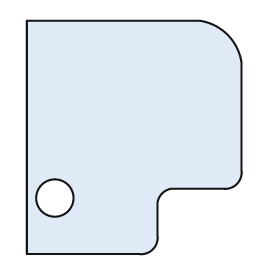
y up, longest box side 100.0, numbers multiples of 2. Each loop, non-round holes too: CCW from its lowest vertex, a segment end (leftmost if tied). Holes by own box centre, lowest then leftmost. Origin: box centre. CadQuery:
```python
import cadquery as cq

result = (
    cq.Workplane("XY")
    .moveTo(-46.0, -50.0)
    .lineTo(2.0, -50.0)
    .threePointArc((8.0, -48.0), (10.0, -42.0))
    .lineTo(10.0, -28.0)
    .threePointArc((12.0, -24.0), (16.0, -22.0))
    .lineTo(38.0, -22.0)
    .threePointArc((44.0, -20.0), (46.0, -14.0))
    .lineTo(46.0, 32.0)
    .threePointArc((40.0, 44.0), (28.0, 50.0))
    .lineTo(-46.0, 50.0)
    .close()
    .moveTo(-34.0, -26.0)
    .circle(8.0)
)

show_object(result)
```